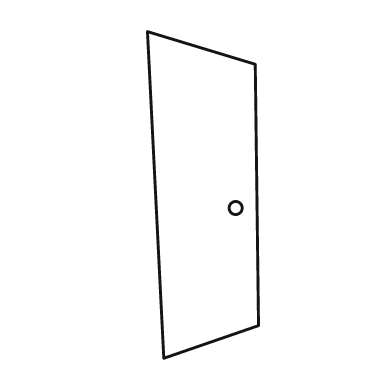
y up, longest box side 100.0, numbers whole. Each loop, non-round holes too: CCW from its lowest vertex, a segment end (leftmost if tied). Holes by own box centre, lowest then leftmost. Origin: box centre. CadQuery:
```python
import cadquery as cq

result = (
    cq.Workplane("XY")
    .moveTo(-12.0, -50.0)
    .lineTo(17.0, -40.0)
    .lineTo(16.0, 40.0)
    .lineTo(-17.0, 50.0)
    .close()
    .moveTo(10.0, -4.0)
    .circle(2.0)
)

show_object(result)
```